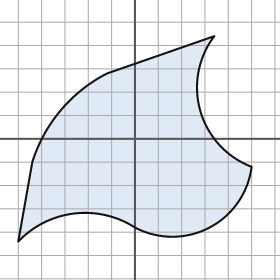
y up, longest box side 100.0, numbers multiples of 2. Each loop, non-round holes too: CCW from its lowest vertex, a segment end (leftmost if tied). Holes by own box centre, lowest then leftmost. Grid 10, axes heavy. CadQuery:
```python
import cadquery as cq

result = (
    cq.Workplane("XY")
    .moveTo(-50.0, -44.0)
    .threePointArc((-26.0, -32.0), (0.0, -38.0))
    .threePointArc((32.0, -38.0), (50.0, -12.0))
    .threePointArc((28.0, 12.0), (34.0, 44.0))
    .lineTo(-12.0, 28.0)
    .threePointArc((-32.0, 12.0), (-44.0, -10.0))
    .close()
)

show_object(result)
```